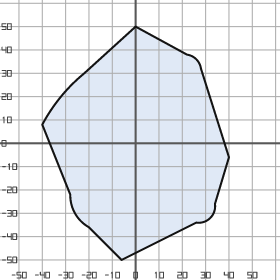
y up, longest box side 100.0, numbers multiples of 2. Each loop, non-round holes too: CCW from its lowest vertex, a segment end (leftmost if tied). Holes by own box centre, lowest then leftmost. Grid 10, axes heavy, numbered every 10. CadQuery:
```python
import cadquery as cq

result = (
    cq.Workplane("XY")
    .moveTo(-6.0, -50.0)
    .lineTo(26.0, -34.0)
    .threePointArc((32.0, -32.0), (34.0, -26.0))
    .lineTo(40.0, -6.0)
    .lineTo(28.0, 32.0)
    .threePointArc((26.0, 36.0), (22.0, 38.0))
    .lineTo(0.0, 50.0)
    .lineTo(-22.0, 30.0)
    .threePointArc((-32.0, 20.0), (-40.0, 8.0))
    .lineTo(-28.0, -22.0)
    .threePointArc((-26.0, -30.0), (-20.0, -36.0))
    .close()
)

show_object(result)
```